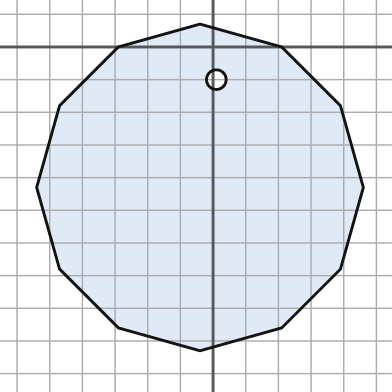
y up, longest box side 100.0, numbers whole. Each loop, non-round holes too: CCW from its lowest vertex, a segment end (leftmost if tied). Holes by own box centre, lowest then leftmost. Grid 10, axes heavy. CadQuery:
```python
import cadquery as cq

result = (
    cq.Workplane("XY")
    .moveTo(-4.0, -93.0)
    .lineTo(21.0, -86.0)
    .lineTo(39.0, -68.0)
    .lineTo(46.0, -43.0)
    .lineTo(39.0, -18.0)
    .lineTo(21.0, 0.0)
    .lineTo(-4.0, 7.0)
    .lineTo(-29.0, 0.0)
    .lineTo(-47.0, -18.0)
    .lineTo(-54.0, -43.0)
    .lineTo(-47.0, -68.0)
    .lineTo(-29.0, -86.0)
    .close()
    .moveTo(1.0, -10.0)
    .circle(3.0)
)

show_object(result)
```